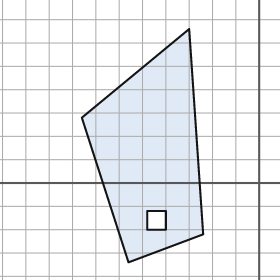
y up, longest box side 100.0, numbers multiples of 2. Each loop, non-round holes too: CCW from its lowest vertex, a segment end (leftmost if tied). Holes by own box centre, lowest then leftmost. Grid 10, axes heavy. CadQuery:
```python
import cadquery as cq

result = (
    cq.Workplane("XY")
    .moveTo(-56.0, -34.0)
    .lineTo(-24.0, -22.0)
    .lineTo(-30.0, 66.0)
    .lineTo(-76.0, 28.0)
    .close()
    .moveTo(-48.0, -20.0)
    .lineTo(-40.0, -20.0)
    .lineTo(-40.0, -12.0)
    .lineTo(-48.0, -12.0)
    .close()
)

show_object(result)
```